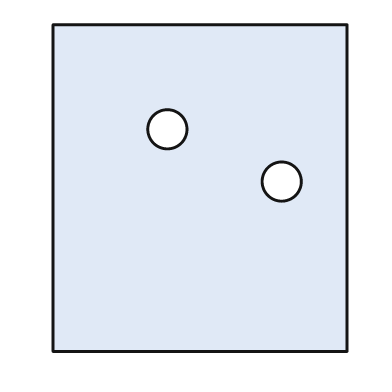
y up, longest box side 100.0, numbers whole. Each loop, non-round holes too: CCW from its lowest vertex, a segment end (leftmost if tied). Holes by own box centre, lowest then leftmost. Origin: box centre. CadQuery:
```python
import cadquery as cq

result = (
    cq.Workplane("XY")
    .moveTo(-45.0, -50.0)
    .lineTo(45.0, -50.0)
    .lineTo(45.0, 50.0)
    .lineTo(-45.0, 50.0)
    .close()
    .moveTo(25.0, 2.0)
    .circle(6.0)
    .moveTo(-10.0, 18.0)
    .circle(6.0)
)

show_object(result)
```